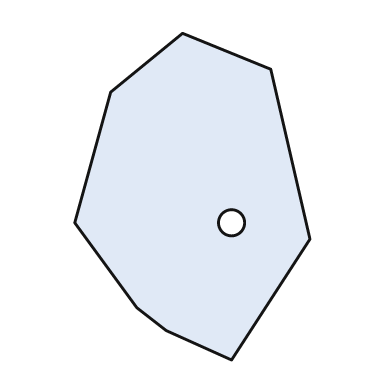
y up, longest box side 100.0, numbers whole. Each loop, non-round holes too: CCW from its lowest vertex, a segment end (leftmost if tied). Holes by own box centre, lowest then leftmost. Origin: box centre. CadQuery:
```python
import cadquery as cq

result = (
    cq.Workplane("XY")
    .moveTo(12.0, -50.0)
    .lineTo(36.0, -13.0)
    .lineTo(24.0, 39.0)
    .lineTo(-3.0, 50.0)
    .lineTo(-25.0, 32.0)
    .lineTo(-36.0, -8.0)
    .lineTo(-17.0, -34.0)
    .lineTo(-8.0, -41.0)
    .close()
    .moveTo(12.0, -8.0)
    .circle(4.0)
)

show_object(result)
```